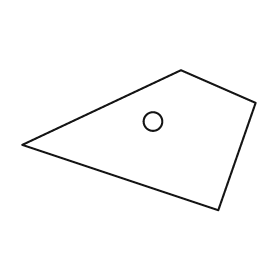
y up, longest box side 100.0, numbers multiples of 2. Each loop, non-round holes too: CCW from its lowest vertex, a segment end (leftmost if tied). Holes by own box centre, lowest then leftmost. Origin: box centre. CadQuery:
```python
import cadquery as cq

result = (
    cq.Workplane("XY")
    .moveTo(34.0, -30.0)
    .lineTo(50.0, 16.0)
    .lineTo(18.0, 30.0)
    .lineTo(-50.0, -2.0)
    .close()
    .moveTo(6.0, 8.0)
    .circle(4.0)
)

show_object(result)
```